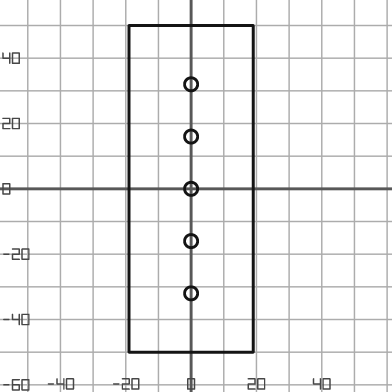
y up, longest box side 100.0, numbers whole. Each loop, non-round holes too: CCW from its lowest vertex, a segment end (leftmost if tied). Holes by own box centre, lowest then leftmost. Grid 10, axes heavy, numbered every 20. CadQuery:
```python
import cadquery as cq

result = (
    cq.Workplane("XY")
    .moveTo(-19.0, -50.0)
    .lineTo(19.0, -50.0)
    .lineTo(19.0, 50.0)
    .lineTo(-19.0, 50.0)
    .close()
    .moveTo(0.0, -32.0)
    .circle(2.0)
    .moveTo(0.0, -16.0)
    .circle(2.0)
    .moveTo(0.0, 0.0)
    .circle(2.0)
    .moveTo(0.0, 16.0)
    .circle(2.0)
    .moveTo(0.0, 32.0)
    .circle(2.0)
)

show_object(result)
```